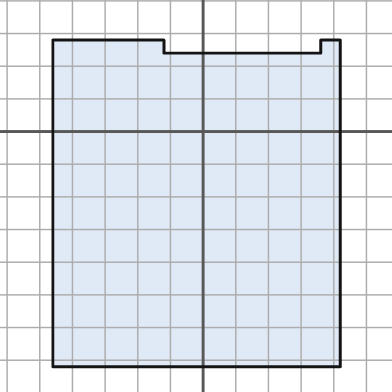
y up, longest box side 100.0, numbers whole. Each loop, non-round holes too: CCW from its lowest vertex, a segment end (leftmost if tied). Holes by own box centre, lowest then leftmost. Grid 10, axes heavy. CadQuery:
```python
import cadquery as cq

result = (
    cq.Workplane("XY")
    .moveTo(-46.0, -72.0)
    .lineTo(42.0, -72.0)
    .lineTo(42.0, 28.0)
    .lineTo(36.0, 28.0)
    .lineTo(36.0, 24.0)
    .lineTo(-12.0, 24.0)
    .lineTo(-12.0, 28.0)
    .lineTo(-46.0, 28.0)
    .close()
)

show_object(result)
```